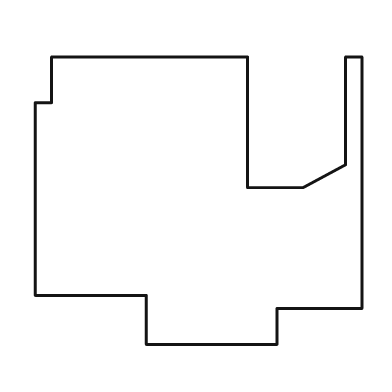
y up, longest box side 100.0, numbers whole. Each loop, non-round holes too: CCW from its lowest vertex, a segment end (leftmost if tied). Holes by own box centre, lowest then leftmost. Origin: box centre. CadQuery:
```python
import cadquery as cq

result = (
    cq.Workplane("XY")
    .moveTo(-16.0, -44.0)
    .lineTo(24.0, -44.0)
    .lineTo(24.0, -33.0)
    .lineTo(50.0, -33.0)
    .lineTo(50.0, 44.0)
    .lineTo(45.0, 44.0)
    .lineTo(45.0, 11.0)
    .lineTo(32.0, 4.0)
    .lineTo(15.0, 4.0)
    .lineTo(15.0, 44.0)
    .lineTo(-45.0, 44.0)
    .lineTo(-45.0, 30.0)
    .lineTo(-50.0, 30.0)
    .lineTo(-50.0, -29.0)
    .lineTo(-16.0, -29.0)
    .close()
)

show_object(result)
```